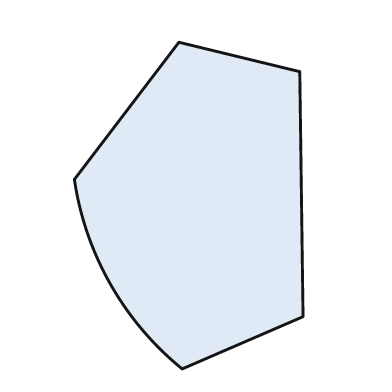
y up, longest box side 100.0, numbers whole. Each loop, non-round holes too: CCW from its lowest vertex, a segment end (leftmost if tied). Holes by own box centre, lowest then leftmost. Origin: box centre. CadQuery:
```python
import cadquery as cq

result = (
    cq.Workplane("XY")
    .moveTo(-2.0, -50.0)
    .lineTo(35.0, -34.0)
    .lineTo(34.0, 41.0)
    .lineTo(-3.0, 50.0)
    .lineTo(-35.0, 8.0)
    .threePointArc((-24.0, -24.0), (-2.0, -50.0))
    .close()
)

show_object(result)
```